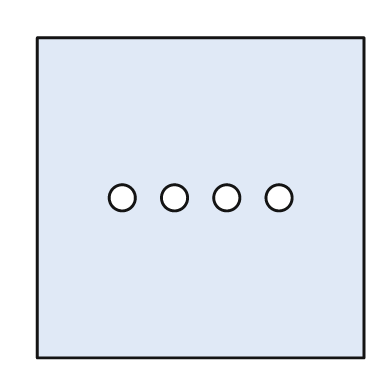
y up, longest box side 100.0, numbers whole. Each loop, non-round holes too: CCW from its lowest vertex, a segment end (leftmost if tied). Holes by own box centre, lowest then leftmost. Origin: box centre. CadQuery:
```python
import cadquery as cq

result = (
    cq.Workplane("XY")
    .moveTo(-50.0, -49.0)
    .lineTo(50.0, -49.0)
    .lineTo(50.0, 49.0)
    .lineTo(-50.0, 49.0)
    .close()
    .moveTo(-24.0, 0.0)
    .circle(4.0)
    .moveTo(-8.0, 0.0)
    .circle(4.0)
    .moveTo(8.0, 0.0)
    .circle(4.0)
    .moveTo(24.0, 0.0)
    .circle(4.0)
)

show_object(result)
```